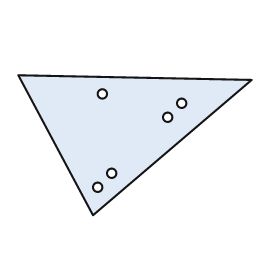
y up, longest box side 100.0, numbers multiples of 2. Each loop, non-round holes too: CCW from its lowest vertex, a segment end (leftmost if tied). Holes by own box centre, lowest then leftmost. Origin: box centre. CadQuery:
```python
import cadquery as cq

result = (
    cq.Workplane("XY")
    .moveTo(-18.0, -30.0)
    .lineTo(50.0, 28.0)
    .lineTo(-50.0, 30.0)
    .close()
    .moveTo(-16.0, -18.0)
    .circle(2.0)
    .moveTo(-10.0, -12.0)
    .circle(2.0)
    .moveTo(14.0, 12.0)
    .circle(2.0)
    .moveTo(20.0, 18.0)
    .circle(2.0)
    .moveTo(-14.0, 22.0)
    .circle(2.0)
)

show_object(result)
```